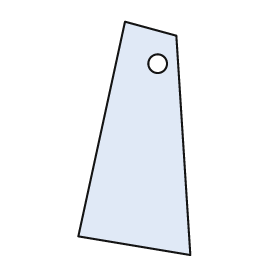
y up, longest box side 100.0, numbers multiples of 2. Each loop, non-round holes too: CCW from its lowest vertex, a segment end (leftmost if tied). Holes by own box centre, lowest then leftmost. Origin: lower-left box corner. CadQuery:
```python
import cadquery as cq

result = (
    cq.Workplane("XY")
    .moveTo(48.0, 0.0)
    .lineTo(42.0, 94.0)
    .lineTo(20.0, 100.0)
    .lineTo(0.0, 8.0)
    .close()
    .moveTo(34.0, 82.0)
    .circle(4.0)
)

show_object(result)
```